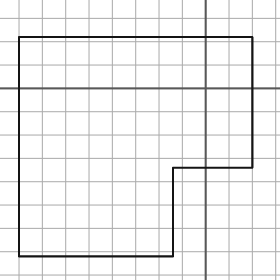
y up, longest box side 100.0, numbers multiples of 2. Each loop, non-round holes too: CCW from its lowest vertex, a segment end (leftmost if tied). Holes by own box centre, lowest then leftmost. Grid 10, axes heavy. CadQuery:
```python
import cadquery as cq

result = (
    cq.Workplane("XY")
    .moveTo(-80.0, -72.0)
    .lineTo(-14.0, -72.0)
    .lineTo(-14.0, -34.0)
    .lineTo(20.0, -34.0)
    .lineTo(20.0, 22.0)
    .lineTo(-80.0, 22.0)
    .close()
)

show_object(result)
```